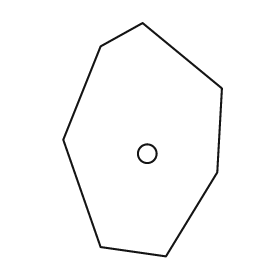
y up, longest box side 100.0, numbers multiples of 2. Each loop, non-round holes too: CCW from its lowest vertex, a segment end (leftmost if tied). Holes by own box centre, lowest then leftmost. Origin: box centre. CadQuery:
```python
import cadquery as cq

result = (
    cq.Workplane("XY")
    .moveTo(10.0, -50.0)
    .lineTo(32.0, -14.0)
    .lineTo(34.0, 22.0)
    .lineTo(0.0, 50.0)
    .lineTo(-18.0, 40.0)
    .lineTo(-34.0, 0.0)
    .lineTo(-18.0, -46.0)
    .close()
    .moveTo(2.0, -6.0)
    .circle(4.0)
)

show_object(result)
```